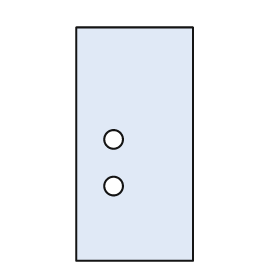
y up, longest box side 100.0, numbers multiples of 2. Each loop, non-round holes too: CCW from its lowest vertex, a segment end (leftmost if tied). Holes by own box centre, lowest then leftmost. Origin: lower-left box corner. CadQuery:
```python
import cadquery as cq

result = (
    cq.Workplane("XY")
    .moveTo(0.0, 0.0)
    .lineTo(50.0, 0.0)
    .lineTo(50.0, 100.0)
    .lineTo(0.0, 100.0)
    .close()
    .moveTo(16.0, 32.0)
    .circle(4.0)
    .moveTo(16.0, 52.0)
    .circle(4.0)
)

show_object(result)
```